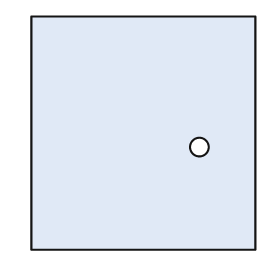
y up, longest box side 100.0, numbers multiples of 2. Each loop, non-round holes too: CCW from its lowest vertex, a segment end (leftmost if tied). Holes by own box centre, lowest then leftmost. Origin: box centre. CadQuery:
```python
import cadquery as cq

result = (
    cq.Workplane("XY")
    .moveTo(-48.0, -50.0)
    .lineTo(48.0, -50.0)
    .lineTo(48.0, 50.0)
    .lineTo(-48.0, 50.0)
    .close()
    .moveTo(24.0, -6.0)
    .circle(4.0)
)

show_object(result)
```